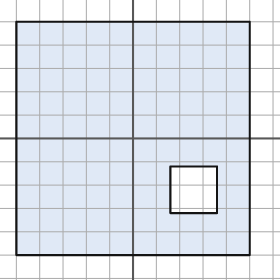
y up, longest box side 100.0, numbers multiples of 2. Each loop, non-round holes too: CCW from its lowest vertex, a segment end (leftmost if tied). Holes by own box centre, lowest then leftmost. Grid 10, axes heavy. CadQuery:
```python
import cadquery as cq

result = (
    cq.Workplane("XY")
    .moveTo(-50.0, -50.0)
    .lineTo(50.0, -50.0)
    .lineTo(50.0, 50.0)
    .lineTo(-50.0, 50.0)
    .close()
    .moveTo(16.0, -32.0)
    .lineTo(36.0, -32.0)
    .lineTo(36.0, -12.0)
    .lineTo(16.0, -12.0)
    .close()
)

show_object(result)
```